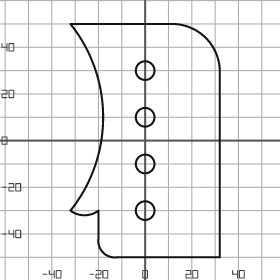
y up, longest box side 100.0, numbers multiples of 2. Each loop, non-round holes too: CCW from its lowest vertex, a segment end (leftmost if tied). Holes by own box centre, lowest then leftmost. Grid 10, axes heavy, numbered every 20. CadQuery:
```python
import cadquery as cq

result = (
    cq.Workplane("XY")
    .moveTo(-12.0, -50.0)
    .lineTo(32.0, -50.0)
    .lineTo(32.0, 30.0)
    .threePointArc((26.0, 44.0), (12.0, 50.0))
    .lineTo(-32.0, 50.0)
    .threePointArc((-18.0, 10.0), (-32.0, -30.0))
    .threePointArc((-26.0, -32.0), (-20.0, -30.0))
    .lineTo(-20.0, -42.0)
    .threePointArc((-18.0, -48.0), (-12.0, -50.0))
    .close()
    .moveTo(0.0, -30.0)
    .circle(4.0)
    .moveTo(0.0, -10.0)
    .circle(4.0)
    .moveTo(0.0, 10.0)
    .circle(4.0)
    .moveTo(0.0, 30.0)
    .circle(4.0)
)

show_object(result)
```